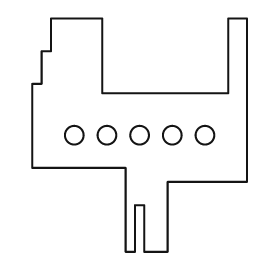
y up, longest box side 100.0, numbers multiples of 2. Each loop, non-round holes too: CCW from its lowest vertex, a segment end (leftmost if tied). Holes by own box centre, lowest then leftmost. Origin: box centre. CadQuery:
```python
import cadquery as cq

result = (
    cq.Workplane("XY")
    .moveTo(-6.0, -50.0)
    .lineTo(-2.0, -50.0)
    .lineTo(-2.0, -30.0)
    .lineTo(2.0, -30.0)
    .lineTo(2.0, -50.0)
    .lineTo(12.0, -50.0)
    .lineTo(12.0, -20.0)
    .lineTo(46.0, -20.0)
    .lineTo(46.0, 50.0)
    .lineTo(38.0, 50.0)
    .lineTo(38.0, 18.0)
    .lineTo(-16.0, 18.0)
    .lineTo(-16.0, 50.0)
    .lineTo(-38.0, 50.0)
    .lineTo(-38.0, 36.0)
    .lineTo(-42.0, 36.0)
    .lineTo(-42.0, 22.0)
    .lineTo(-46.0, 22.0)
    .lineTo(-46.0, -14.0)
    .lineTo(-6.0, -14.0)
    .close()
    .moveTo(-28.0, 0.0)
    .circle(4.0)
    .moveTo(-14.0, 0.0)
    .circle(4.0)
    .moveTo(0.0, 0.0)
    .circle(4.0)
    .moveTo(14.0, 0.0)
    .circle(4.0)
    .moveTo(28.0, 0.0)
    .circle(4.0)
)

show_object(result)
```